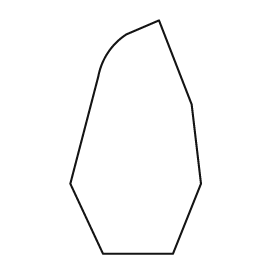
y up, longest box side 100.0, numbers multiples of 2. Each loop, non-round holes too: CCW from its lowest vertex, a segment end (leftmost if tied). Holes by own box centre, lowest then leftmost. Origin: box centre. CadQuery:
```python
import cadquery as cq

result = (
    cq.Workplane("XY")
    .moveTo(-14.0, -50.0)
    .lineTo(16.0, -50.0)
    .lineTo(28.0, -20.0)
    .lineTo(24.0, 14.0)
    .lineTo(10.0, 50.0)
    .lineTo(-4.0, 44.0)
    .threePointArc((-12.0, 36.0), (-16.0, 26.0))
    .lineTo(-28.0, -20.0)
    .close()
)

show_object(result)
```